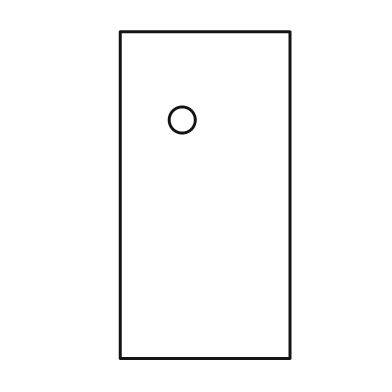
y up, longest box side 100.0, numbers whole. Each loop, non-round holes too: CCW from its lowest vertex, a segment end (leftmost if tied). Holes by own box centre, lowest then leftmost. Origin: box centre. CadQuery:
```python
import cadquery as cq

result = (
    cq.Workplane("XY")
    .moveTo(-26.0, -50.0)
    .lineTo(26.0, -50.0)
    .lineTo(26.0, 50.0)
    .lineTo(-26.0, 50.0)
    .close()
    .moveTo(-7.0, 23.0)
    .circle(4.0)
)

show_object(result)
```